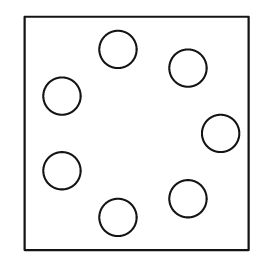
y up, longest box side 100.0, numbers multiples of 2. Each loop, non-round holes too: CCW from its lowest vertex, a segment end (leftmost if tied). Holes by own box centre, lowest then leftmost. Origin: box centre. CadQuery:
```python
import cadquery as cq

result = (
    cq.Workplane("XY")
    .moveTo(-48.0, -50.0)
    .lineTo(48.0, -50.0)
    .lineTo(48.0, 50.0)
    .lineTo(-48.0, 50.0)
    .close()
    .moveTo(-8.0, -36.0)
    .circle(8.0)
    .moveTo(22.0, -28.0)
    .circle(8.0)
    .moveTo(-32.0, -16.0)
    .circle(8.0)
    .moveTo(36.0, 0.0)
    .circle(8.0)
    .moveTo(-32.0, 16.0)
    .circle(8.0)
    .moveTo(22.0, 28.0)
    .circle(8.0)
    .moveTo(-8.0, 36.0)
    .circle(8.0)
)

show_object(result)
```